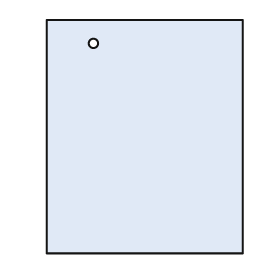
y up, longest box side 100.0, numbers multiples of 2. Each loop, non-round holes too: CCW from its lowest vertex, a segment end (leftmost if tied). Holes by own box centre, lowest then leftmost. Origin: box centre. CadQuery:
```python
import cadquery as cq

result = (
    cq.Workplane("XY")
    .moveTo(-42.0, -50.0)
    .lineTo(42.0, -50.0)
    .lineTo(42.0, 50.0)
    .lineTo(-42.0, 50.0)
    .close()
    .moveTo(-22.0, 40.0)
    .circle(2.0)
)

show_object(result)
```